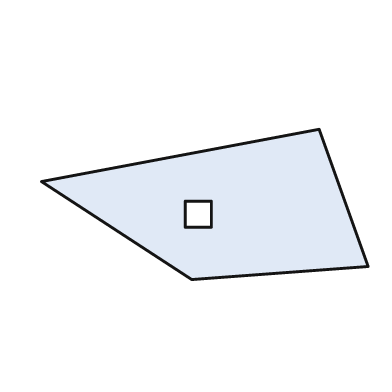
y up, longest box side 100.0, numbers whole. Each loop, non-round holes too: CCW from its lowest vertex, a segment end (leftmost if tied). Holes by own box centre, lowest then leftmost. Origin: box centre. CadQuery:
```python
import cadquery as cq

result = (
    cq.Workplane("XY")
    .moveTo(-4.0, -23.0)
    .lineTo(50.0, -19.0)
    .lineTo(35.0, 23.0)
    .lineTo(-50.0, 7.0)
    .close()
    .moveTo(-6.0, -7.0)
    .lineTo(2.0, -7.0)
    .lineTo(2.0, 1.0)
    .lineTo(-6.0, 1.0)
    .close()
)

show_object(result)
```